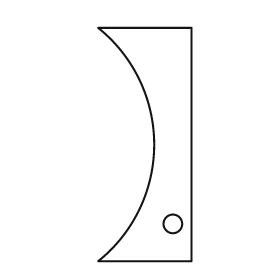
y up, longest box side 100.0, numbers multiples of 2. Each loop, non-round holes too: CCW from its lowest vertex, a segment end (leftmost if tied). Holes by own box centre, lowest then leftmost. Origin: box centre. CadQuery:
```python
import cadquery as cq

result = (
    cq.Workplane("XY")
    .moveTo(-20.0, -50.0)
    .lineTo(20.0, -50.0)
    .lineTo(20.0, 50.0)
    .lineTo(-20.0, 50.0)
    .threePointArc((4.0, 0.0), (-20.0, -50.0))
    .close()
    .moveTo(12.0, -34.0)
    .circle(4.0)
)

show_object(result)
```